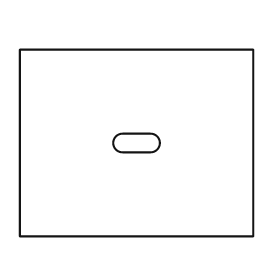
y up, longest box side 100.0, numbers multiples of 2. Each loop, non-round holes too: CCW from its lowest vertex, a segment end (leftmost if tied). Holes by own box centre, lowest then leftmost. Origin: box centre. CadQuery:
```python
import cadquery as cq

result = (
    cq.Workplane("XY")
    .moveTo(-50.0, -40.0)
    .lineTo(50.0, -40.0)
    .lineTo(50.0, 40.0)
    .lineTo(-50.0, 40.0)
    .close()
    .moveTo(-6.0, -4.0)
    .lineTo(6.0, -4.0)
    .threePointArc((10.0, 0.0), (6.0, 4.0))
    .lineTo(-6.0, 4.0)
    .threePointArc((-10.0, 0.0), (-6.0, -4.0))
    .close()
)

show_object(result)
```